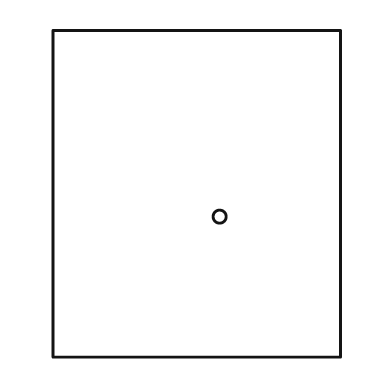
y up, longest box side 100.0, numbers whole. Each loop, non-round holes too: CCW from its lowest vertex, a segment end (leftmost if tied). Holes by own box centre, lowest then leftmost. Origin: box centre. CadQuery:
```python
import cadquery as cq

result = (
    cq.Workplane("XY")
    .moveTo(-44.0, -50.0)
    .lineTo(44.0, -50.0)
    .lineTo(44.0, 50.0)
    .lineTo(-44.0, 50.0)
    .close()
    .moveTo(7.0, -7.0)
    .circle(2.0)
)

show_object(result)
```